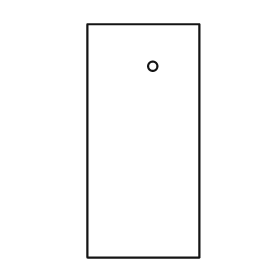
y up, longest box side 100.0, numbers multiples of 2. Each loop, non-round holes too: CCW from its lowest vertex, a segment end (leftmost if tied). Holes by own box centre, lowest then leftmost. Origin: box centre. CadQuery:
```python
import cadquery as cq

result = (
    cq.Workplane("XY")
    .moveTo(-24.0, -50.0)
    .lineTo(24.0, -50.0)
    .lineTo(24.0, 50.0)
    .lineTo(-24.0, 50.0)
    .close()
    .moveTo(4.0, 32.0)
    .circle(2.0)
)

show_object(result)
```